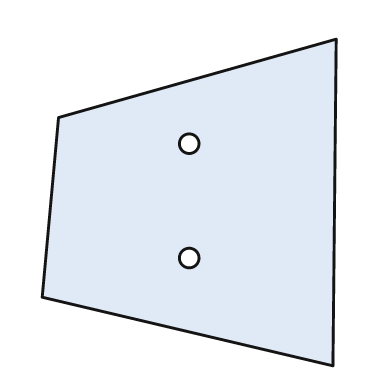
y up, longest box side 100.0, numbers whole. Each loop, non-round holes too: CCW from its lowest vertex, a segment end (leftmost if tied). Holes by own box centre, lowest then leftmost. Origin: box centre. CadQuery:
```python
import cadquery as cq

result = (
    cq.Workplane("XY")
    .moveTo(44.0, -50.0)
    .lineTo(45.0, 50.0)
    .lineTo(-40.0, 26.0)
    .lineTo(-45.0, -29.0)
    .close()
    .moveTo(0.0, -17.0)
    .circle(3.0)
    .moveTo(0.0, 18.0)
    .circle(3.0)
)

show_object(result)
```